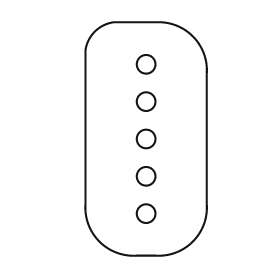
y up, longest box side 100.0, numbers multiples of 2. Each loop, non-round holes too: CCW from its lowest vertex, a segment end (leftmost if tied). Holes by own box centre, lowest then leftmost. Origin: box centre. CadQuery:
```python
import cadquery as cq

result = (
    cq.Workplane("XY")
    .moveTo(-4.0, -50.0)
    .lineTo(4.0, -50.0)
    .threePointArc((20.0, -44.0), (26.0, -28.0))
    .lineTo(26.0, 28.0)
    .threePointArc((20.0, 44.0), (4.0, 50.0))
    .lineTo(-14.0, 50.0)
    .threePointArc((-22.0, 46.0), (-26.0, 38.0))
    .lineTo(-26.0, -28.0)
    .threePointArc((-20.0, -44.0), (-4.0, -50.0))
    .close()
    .moveTo(0.0, -32.0)
    .circle(4.0)
    .moveTo(0.0, -16.0)
    .circle(4.0)
    .moveTo(0.0, 0.0)
    .circle(4.0)
    .moveTo(0.0, 16.0)
    .circle(4.0)
    .moveTo(0.0, 32.0)
    .circle(4.0)
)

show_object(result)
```